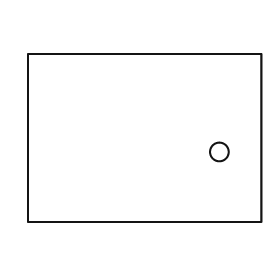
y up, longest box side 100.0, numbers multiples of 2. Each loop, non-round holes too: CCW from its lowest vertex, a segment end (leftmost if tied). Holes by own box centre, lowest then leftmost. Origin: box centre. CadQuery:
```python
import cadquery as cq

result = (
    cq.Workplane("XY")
    .moveTo(-50.0, -36.0)
    .lineTo(50.0, -36.0)
    .lineTo(50.0, 36.0)
    .lineTo(-50.0, 36.0)
    .close()
    .moveTo(32.0, -6.0)
    .circle(4.0)
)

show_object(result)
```